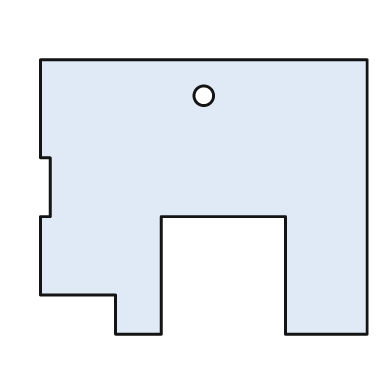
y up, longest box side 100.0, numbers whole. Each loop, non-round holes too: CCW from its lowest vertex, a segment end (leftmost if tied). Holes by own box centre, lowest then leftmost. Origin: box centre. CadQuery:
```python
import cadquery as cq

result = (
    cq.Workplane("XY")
    .moveTo(-27.0, -42.0)
    .lineTo(-13.0, -42.0)
    .lineTo(-13.0, -6.0)
    .lineTo(25.0, -6.0)
    .lineTo(25.0, -42.0)
    .lineTo(50.0, -42.0)
    .lineTo(50.0, 42.0)
    .lineTo(-50.0, 42.0)
    .lineTo(-50.0, 12.0)
    .lineTo(-47.0, 12.0)
    .lineTo(-47.0, -6.0)
    .lineTo(-50.0, -6.0)
    .lineTo(-50.0, -30.0)
    .lineTo(-27.0, -30.0)
    .close()
    .moveTo(0.0, 31.0)
    .circle(3.0)
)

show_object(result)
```